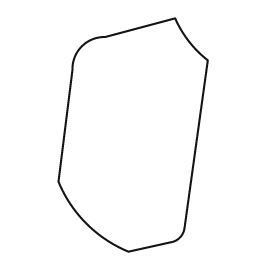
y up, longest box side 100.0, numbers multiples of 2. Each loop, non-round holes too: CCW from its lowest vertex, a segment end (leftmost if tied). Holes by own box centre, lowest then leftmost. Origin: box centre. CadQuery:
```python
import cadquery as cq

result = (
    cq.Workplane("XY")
    .moveTo(-2.0, -50.0)
    .lineTo(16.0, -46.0)
    .threePointArc((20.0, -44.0), (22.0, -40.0))
    .lineTo(32.0, 32.0)
    .threePointArc((24.0, 40.0), (18.0, 50.0))
    .lineTo(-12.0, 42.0)
    .threePointArc((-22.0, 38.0), (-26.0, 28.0))
    .lineTo(-32.0, -20.0)
    .threePointArc((-20.0, -38.0), (-2.0, -50.0))
    .close()
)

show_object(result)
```